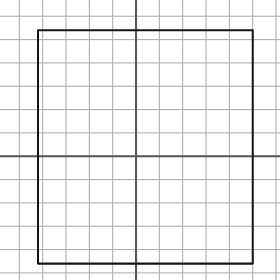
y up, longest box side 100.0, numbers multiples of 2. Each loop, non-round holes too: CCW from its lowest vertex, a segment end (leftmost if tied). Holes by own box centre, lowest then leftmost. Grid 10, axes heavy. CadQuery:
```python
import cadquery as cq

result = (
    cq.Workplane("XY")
    .moveTo(-42.0, -46.0)
    .lineTo(50.0, -46.0)
    .lineTo(50.0, 54.0)
    .lineTo(-42.0, 54.0)
    .close()
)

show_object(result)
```